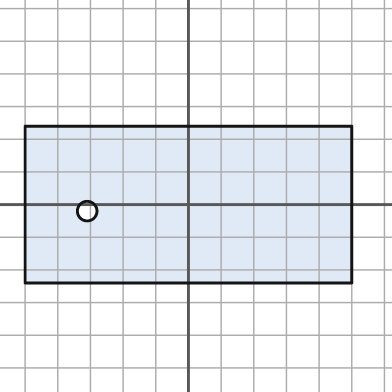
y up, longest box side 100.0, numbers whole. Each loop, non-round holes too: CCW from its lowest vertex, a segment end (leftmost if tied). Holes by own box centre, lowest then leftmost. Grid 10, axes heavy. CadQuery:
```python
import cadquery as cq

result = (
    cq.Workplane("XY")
    .moveTo(-50.0, -24.0)
    .lineTo(50.0, -24.0)
    .lineTo(50.0, 24.0)
    .lineTo(-50.0, 24.0)
    .close()
    .moveTo(-31.0, -2.0)
    .circle(3.0)
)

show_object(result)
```